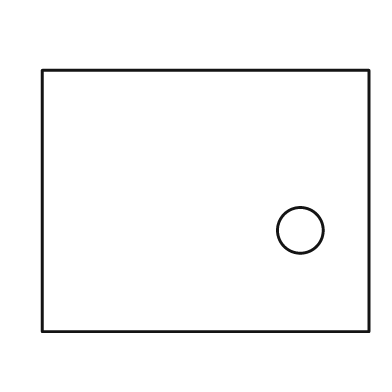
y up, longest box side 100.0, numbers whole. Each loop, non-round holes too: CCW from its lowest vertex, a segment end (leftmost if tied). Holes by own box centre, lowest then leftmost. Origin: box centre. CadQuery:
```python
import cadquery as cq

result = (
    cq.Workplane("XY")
    .moveTo(-50.0, -40.0)
    .lineTo(50.0, -40.0)
    .lineTo(50.0, 40.0)
    .lineTo(-50.0, 40.0)
    .close()
    .moveTo(29.0, -9.0)
    .circle(7.0)
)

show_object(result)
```